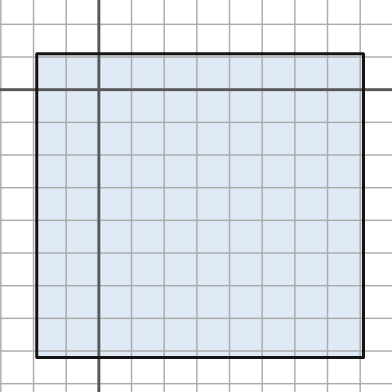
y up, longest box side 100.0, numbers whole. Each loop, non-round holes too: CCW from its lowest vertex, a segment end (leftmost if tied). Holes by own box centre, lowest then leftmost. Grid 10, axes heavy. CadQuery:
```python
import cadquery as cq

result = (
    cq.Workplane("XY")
    .moveTo(-19.0, -82.0)
    .lineTo(81.0, -82.0)
    .lineTo(81.0, 11.0)
    .lineTo(-19.0, 11.0)
    .close()
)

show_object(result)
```